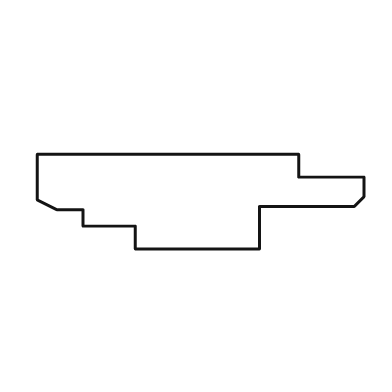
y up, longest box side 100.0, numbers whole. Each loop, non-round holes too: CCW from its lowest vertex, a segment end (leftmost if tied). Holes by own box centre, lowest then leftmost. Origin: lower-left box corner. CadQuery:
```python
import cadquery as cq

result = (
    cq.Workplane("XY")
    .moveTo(30.0, 0.0)
    .lineTo(68.0, 0.0)
    .lineTo(68.0, 13.0)
    .lineTo(97.0, 13.0)
    .lineTo(100.0, 16.0)
    .lineTo(100.0, 22.0)
    .lineTo(80.0, 22.0)
    .lineTo(80.0, 29.0)
    .lineTo(0.0, 29.0)
    .lineTo(0.0, 15.0)
    .lineTo(6.0, 12.0)
    .lineTo(14.0, 12.0)
    .lineTo(14.0, 7.0)
    .lineTo(30.0, 7.0)
    .close()
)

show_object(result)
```